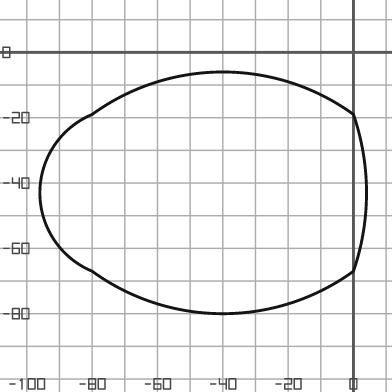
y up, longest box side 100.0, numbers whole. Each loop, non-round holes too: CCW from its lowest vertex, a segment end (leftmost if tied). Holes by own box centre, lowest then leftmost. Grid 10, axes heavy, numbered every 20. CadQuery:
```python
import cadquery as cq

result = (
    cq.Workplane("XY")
    .moveTo(-80.0, -67.0)
    .threePointArc((-40.0, -80.0), (0.0, -67.0))
    .threePointArc((4.0, -43.0), (0.0, -19.0))
    .threePointArc((-40.0, -6.0), (-80.0, -19.0))
    .threePointArc((-96.0, -43.0), (-80.0, -67.0))
    .close()
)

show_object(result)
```